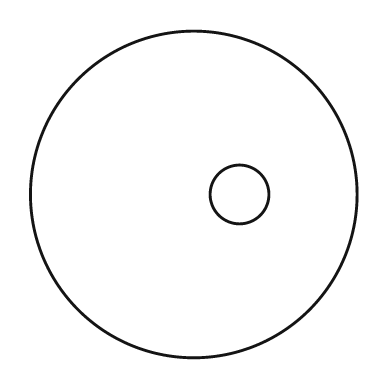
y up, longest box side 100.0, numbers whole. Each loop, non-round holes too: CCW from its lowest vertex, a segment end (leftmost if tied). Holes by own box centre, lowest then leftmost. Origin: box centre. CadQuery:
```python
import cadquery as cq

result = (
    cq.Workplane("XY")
    .moveTo(0.0, 0.0)
    .circle(50.0)
    .moveTo(14.0, 0.0)
    .circle(9.0)
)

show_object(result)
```